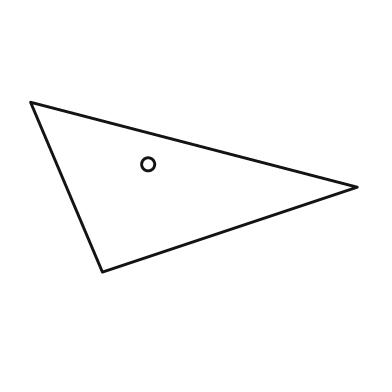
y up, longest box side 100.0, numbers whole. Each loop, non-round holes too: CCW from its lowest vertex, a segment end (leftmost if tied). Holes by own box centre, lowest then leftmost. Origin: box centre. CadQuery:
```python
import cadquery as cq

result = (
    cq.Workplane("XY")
    .moveTo(-28.0, -26.0)
    .lineTo(50.0, 0.0)
    .lineTo(-50.0, 26.0)
    .close()
    .moveTo(-14.0, 7.0)
    .circle(2.0)
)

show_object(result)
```